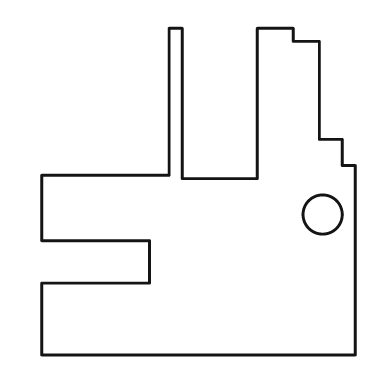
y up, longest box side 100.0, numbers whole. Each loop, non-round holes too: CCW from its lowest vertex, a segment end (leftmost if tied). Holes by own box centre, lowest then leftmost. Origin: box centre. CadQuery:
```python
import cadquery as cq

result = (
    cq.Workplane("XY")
    .moveTo(-48.0, -50.0)
    .lineTo(48.0, -50.0)
    .lineTo(48.0, 8.0)
    .lineTo(44.0, 8.0)
    .lineTo(44.0, 16.0)
    .lineTo(37.0, 16.0)
    .lineTo(37.0, 46.0)
    .lineTo(29.0, 46.0)
    .lineTo(29.0, 50.0)
    .lineTo(18.0, 50.0)
    .lineTo(18.0, 4.0)
    .lineTo(-5.0, 4.0)
    .lineTo(-5.0, 50.0)
    .lineTo(-9.0, 50.0)
    .lineTo(-9.0, 5.0)
    .lineTo(-48.0, 5.0)
    .lineTo(-48.0, -15.0)
    .lineTo(-15.0, -15.0)
    .lineTo(-15.0, -28.0)
    .lineTo(-48.0, -28.0)
    .close()
    .moveTo(38.0, -7.0)
    .circle(6.0)
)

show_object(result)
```